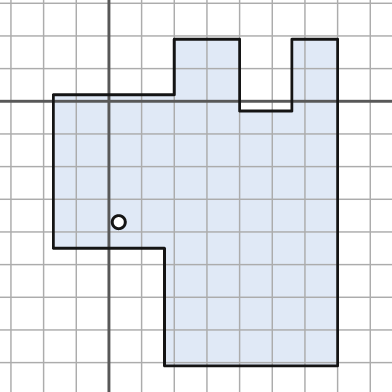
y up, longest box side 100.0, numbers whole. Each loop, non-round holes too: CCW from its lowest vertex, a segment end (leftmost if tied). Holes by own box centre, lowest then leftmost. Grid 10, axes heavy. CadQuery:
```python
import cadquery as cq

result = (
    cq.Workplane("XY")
    .moveTo(17.0, -81.0)
    .lineTo(70.0, -81.0)
    .lineTo(70.0, 19.0)
    .lineTo(56.0, 19.0)
    .lineTo(56.0, -3.0)
    .lineTo(40.0, -3.0)
    .lineTo(40.0, 19.0)
    .lineTo(20.0, 19.0)
    .lineTo(20.0, 2.0)
    .lineTo(-17.0, 2.0)
    .lineTo(-17.0, -45.0)
    .lineTo(17.0, -45.0)
    .close()
    .moveTo(3.0, -37.0)
    .circle(2.0)
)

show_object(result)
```